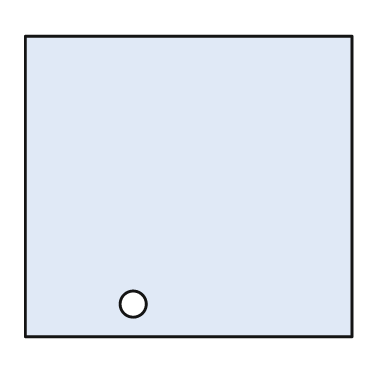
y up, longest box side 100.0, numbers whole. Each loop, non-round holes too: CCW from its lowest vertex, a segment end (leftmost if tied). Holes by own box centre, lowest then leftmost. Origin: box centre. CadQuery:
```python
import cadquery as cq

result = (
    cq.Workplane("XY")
    .moveTo(-50.0, -46.0)
    .lineTo(50.0, -46.0)
    .lineTo(50.0, 46.0)
    .lineTo(-50.0, 46.0)
    .close()
    .moveTo(-17.0, -36.0)
    .circle(4.0)
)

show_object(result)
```